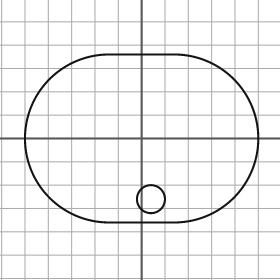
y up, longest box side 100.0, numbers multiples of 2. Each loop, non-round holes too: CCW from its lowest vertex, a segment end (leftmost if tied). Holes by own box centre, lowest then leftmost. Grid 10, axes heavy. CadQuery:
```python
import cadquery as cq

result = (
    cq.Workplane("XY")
    .moveTo(-14.0, -36.0)
    .lineTo(14.0, -36.0)
    .threePointArc((50.0, 0.0), (14.0, 36.0))
    .lineTo(-14.0, 36.0)
    .threePointArc((-50.0, 0.0), (-14.0, -36.0))
    .close()
    .moveTo(4.0, -26.0)
    .circle(6.0)
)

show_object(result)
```